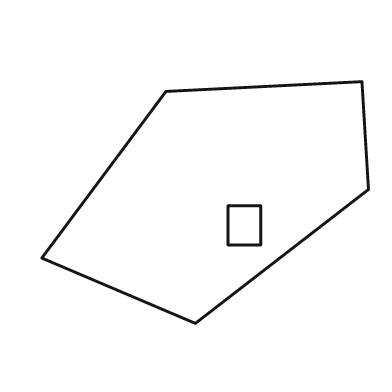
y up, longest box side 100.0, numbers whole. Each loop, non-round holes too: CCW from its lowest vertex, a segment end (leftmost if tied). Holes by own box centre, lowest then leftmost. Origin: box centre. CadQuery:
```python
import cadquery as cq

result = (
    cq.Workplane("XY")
    .moveTo(-3.0, -37.0)
    .lineTo(50.0, 4.0)
    .lineTo(48.0, 37.0)
    .lineTo(-12.0, 34.0)
    .lineTo(-50.0, -17.0)
    .close()
    .moveTo(7.0, -13.0)
    .lineTo(17.0, -13.0)
    .lineTo(17.0, -1.0)
    .lineTo(7.0, -1.0)
    .close()
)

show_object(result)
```